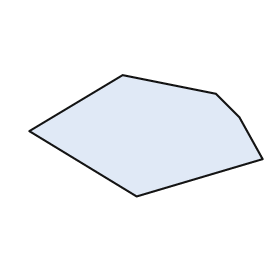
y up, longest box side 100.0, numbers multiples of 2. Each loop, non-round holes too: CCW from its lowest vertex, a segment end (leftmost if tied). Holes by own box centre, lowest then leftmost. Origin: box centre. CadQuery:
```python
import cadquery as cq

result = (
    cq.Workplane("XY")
    .moveTo(-4.0, -26.0)
    .lineTo(50.0, -10.0)
    .lineTo(40.0, 8.0)
    .lineTo(30.0, 18.0)
    .lineTo(-10.0, 26.0)
    .lineTo(-50.0, 2.0)
    .close()
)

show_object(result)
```